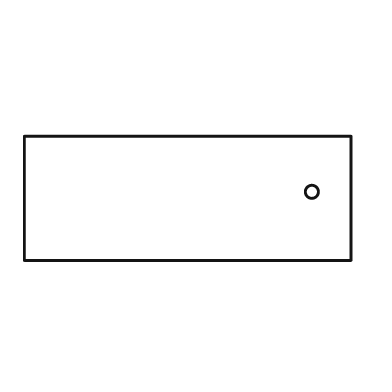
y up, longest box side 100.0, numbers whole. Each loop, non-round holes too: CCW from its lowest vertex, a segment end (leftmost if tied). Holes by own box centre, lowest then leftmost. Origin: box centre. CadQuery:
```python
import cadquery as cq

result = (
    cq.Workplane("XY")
    .moveTo(-50.0, -19.0)
    .lineTo(50.0, -19.0)
    .lineTo(50.0, 19.0)
    .lineTo(-50.0, 19.0)
    .close()
    .moveTo(38.0, 2.0)
    .circle(2.0)
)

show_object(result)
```